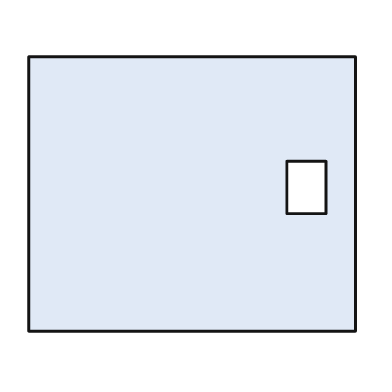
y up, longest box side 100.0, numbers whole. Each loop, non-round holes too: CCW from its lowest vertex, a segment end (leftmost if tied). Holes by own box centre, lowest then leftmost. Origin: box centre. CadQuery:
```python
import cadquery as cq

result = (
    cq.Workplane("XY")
    .moveTo(-50.0, -42.0)
    .lineTo(50.0, -42.0)
    .lineTo(50.0, 42.0)
    .lineTo(-50.0, 42.0)
    .close()
    .moveTo(29.0, -6.0)
    .lineTo(41.0, -6.0)
    .lineTo(41.0, 10.0)
    .lineTo(29.0, 10.0)
    .close()
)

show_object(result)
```